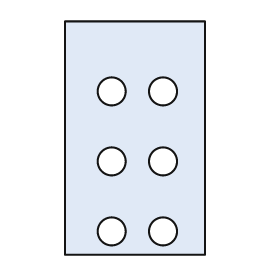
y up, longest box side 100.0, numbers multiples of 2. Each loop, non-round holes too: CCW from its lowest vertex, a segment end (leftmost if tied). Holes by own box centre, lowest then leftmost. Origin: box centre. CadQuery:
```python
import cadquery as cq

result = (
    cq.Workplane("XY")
    .moveTo(-30.0, -50.0)
    .lineTo(30.0, -50.0)
    .lineTo(30.0, 50.0)
    .lineTo(-30.0, 50.0)
    .close()
    .moveTo(-10.0, -40.0)
    .circle(6.0)
    .moveTo(12.0, -40.0)
    .circle(6.0)
    .moveTo(-10.0, -10.0)
    .circle(6.0)
    .moveTo(12.0, -10.0)
    .circle(6.0)
    .moveTo(-10.0, 20.0)
    .circle(6.0)
    .moveTo(12.0, 20.0)
    .circle(6.0)
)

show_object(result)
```